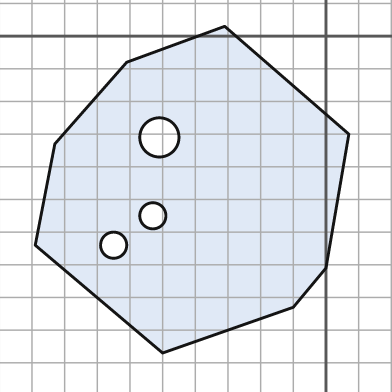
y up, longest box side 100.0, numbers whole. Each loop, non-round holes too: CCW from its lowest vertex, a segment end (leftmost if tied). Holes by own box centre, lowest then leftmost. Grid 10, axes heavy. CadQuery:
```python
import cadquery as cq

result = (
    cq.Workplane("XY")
    .moveTo(-50.0, -97.0)
    .lineTo(-10.0, -83.0)
    .lineTo(0.0, -71.0)
    .lineTo(7.0, -30.0)
    .lineTo(-31.0, 3.0)
    .lineTo(-61.0, -8.0)
    .lineTo(-83.0, -33.0)
    .lineTo(-89.0, -64.0)
    .close()
    .moveTo(-65.0, -64.0)
    .circle(4.0)
    .moveTo(-53.0, -55.0)
    .circle(4.0)
    .moveTo(-51.0, -31.0)
    .circle(6.0)
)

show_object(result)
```